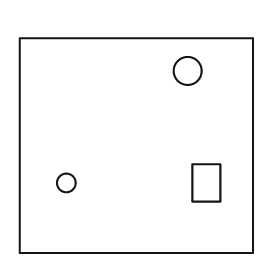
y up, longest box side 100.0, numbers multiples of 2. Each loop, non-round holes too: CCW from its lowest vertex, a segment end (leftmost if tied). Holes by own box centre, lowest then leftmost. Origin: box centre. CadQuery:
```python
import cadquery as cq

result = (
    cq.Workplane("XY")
    .moveTo(-50.0, -46.0)
    .lineTo(50.0, -46.0)
    .lineTo(50.0, 46.0)
    .lineTo(-50.0, 46.0)
    .close()
    .moveTo(-30.0, -16.0)
    .circle(4.0)
    .moveTo(24.0, -24.0)
    .lineTo(36.0, -24.0)
    .lineTo(36.0, -8.0)
    .lineTo(24.0, -8.0)
    .close()
    .moveTo(22.0, 32.0)
    .circle(6.0)
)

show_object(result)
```